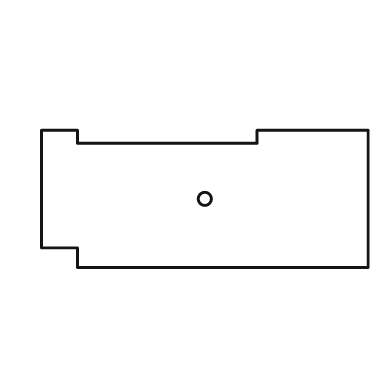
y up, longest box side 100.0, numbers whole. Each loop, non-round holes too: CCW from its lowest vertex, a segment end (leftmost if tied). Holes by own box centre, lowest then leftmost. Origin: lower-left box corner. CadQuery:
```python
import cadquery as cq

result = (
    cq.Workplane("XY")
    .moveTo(11.0, 0.0)
    .lineTo(100.0, 0.0)
    .lineTo(100.0, 42.0)
    .lineTo(66.0, 42.0)
    .lineTo(66.0, 38.0)
    .lineTo(11.0, 38.0)
    .lineTo(11.0, 42.0)
    .lineTo(0.0, 42.0)
    .lineTo(0.0, 6.0)
    .lineTo(11.0, 6.0)
    .close()
    .moveTo(50.0, 21.0)
    .circle(2.0)
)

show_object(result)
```